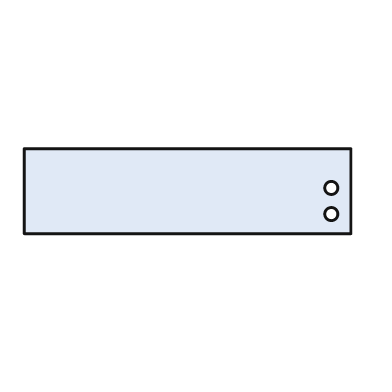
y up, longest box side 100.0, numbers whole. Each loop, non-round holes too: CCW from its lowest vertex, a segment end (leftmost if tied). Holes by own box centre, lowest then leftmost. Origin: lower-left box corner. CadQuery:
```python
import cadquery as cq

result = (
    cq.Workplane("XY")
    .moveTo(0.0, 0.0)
    .lineTo(100.0, 0.0)
    .lineTo(100.0, 26.0)
    .lineTo(0.0, 26.0)
    .close()
    .moveTo(94.0, 6.0)
    .circle(2.0)
    .moveTo(94.0, 14.0)
    .circle(2.0)
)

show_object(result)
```